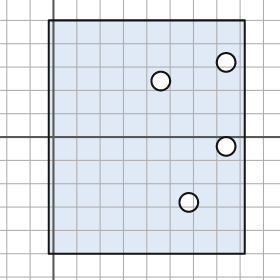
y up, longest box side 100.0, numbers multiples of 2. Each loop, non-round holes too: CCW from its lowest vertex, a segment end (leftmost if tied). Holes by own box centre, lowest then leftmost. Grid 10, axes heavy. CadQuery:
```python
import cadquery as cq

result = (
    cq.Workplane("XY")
    .moveTo(-2.0, -50.0)
    .lineTo(82.0, -50.0)
    .lineTo(82.0, 50.0)
    .lineTo(-2.0, 50.0)
    .close()
    .moveTo(58.0, -28.0)
    .circle(4.0)
    .moveTo(74.0, -4.0)
    .circle(4.0)
    .moveTo(46.0, 24.0)
    .circle(4.0)
    .moveTo(74.0, 32.0)
    .circle(4.0)
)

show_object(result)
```